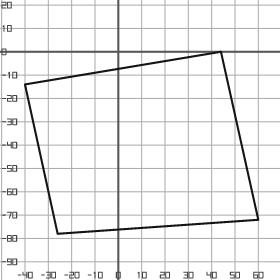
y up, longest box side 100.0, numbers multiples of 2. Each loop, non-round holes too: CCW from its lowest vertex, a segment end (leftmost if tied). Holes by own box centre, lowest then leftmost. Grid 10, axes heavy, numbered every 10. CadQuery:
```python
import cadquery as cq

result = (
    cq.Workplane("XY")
    .moveTo(-26.0, -78.0)
    .lineTo(60.0, -72.0)
    .lineTo(44.0, 0.0)
    .lineTo(-40.0, -14.0)
    .close()
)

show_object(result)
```